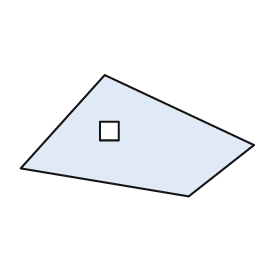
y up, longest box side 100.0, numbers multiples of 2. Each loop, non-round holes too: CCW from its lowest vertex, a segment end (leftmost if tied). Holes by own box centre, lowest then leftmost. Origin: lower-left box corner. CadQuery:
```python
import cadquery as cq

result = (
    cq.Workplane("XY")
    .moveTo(72.0, 0.0)
    .lineTo(100.0, 22.0)
    .lineTo(36.0, 52.0)
    .lineTo(0.0, 12.0)
    .close()
    .moveTo(34.0, 24.0)
    .lineTo(42.0, 24.0)
    .lineTo(42.0, 32.0)
    .lineTo(34.0, 32.0)
    .close()
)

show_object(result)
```